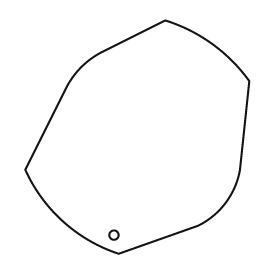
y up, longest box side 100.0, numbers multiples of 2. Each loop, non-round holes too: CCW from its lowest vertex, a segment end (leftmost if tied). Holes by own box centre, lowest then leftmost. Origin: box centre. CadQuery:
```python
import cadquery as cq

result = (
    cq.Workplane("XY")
    .moveTo(-8.0, -50.0)
    .lineTo(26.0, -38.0)
    .threePointArc((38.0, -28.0), (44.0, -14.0))
    .lineTo(48.0, 24.0)
    .threePointArc((32.0, 40.0), (12.0, 50.0))
    .lineTo(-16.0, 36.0)
    .threePointArc((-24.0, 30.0), (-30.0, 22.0))
    .lineTo(-48.0, -14.0)
    .threePointArc((-32.0, -36.0), (-8.0, -50.0))
    .close()
    .moveTo(-10.0, -42.0)
    .circle(2.0)
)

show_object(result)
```